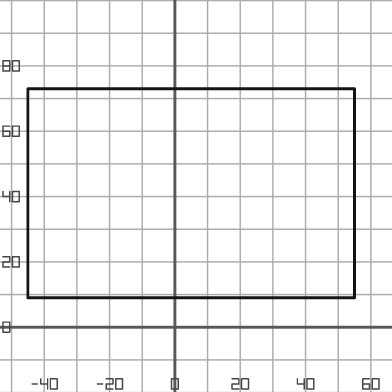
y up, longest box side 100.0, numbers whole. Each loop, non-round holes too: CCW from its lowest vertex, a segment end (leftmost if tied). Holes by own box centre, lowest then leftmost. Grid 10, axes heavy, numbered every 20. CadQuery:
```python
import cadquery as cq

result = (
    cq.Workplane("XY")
    .moveTo(-45.0, 9.0)
    .lineTo(55.0, 9.0)
    .lineTo(55.0, 73.0)
    .lineTo(-45.0, 73.0)
    .close()
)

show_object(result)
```